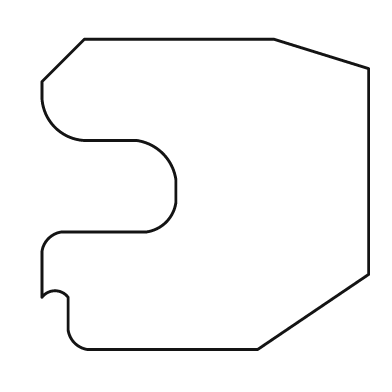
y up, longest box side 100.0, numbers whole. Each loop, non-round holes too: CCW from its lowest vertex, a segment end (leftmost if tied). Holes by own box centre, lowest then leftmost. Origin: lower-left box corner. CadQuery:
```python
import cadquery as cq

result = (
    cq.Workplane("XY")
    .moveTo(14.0, 0.0)
    .lineTo(66.0, 0.0)
    .lineTo(100.0, 23.0)
    .lineTo(100.0, 86.0)
    .lineTo(71.0, 95.0)
    .lineTo(13.0, 95.0)
    .lineTo(0.0, 82.0)
    .lineTo(0.0, 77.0)
    .threePointArc((4.0, 68.0), (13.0, 64.0))
    .lineTo(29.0, 64.0)
    .threePointArc((37.0, 60.0), (41.0, 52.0))
    .lineTo(41.0, 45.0)
    .threePointArc((38.0, 39.0), (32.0, 36.0))
    .lineTo(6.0, 36.0)
    .threePointArc((2.0, 34.0), (0.0, 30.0))
    .lineTo(0.0, 16.0)
    .threePointArc((4.0, 18.0), (8.0, 16.0))
    .lineTo(8.0, 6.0)
    .threePointArc((10.0, 2.0), (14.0, 0.0))
    .close()
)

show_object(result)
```